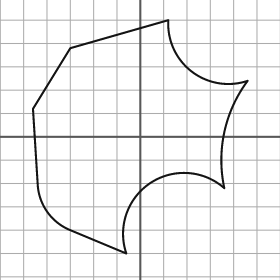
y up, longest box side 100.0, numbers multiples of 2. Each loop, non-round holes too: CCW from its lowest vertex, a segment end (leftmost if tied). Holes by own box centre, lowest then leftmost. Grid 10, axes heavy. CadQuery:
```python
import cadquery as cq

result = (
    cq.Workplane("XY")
    .moveTo(-6.0, -50.0)
    .threePointArc((4.0, -20.0), (36.0, -22.0))
    .threePointArc((36.0, 2.0), (46.0, 24.0))
    .threePointArc((22.0, 28.0), (12.0, 50.0))
    .lineTo(-30.0, 38.0)
    .lineTo(-46.0, 12.0)
    .lineTo(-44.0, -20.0)
    .threePointArc((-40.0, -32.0), (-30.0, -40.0))
    .close()
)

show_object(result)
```